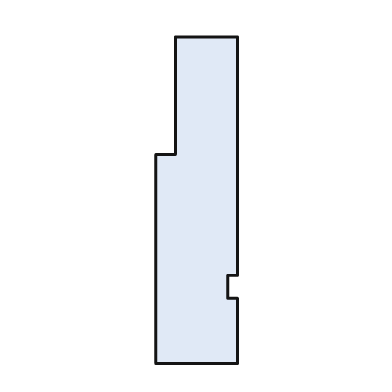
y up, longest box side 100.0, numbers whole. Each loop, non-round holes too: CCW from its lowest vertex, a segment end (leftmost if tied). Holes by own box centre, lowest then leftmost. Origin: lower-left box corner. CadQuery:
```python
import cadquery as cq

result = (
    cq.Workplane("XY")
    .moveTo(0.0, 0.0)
    .lineTo(25.0, 0.0)
    .lineTo(25.0, 20.0)
    .lineTo(22.0, 20.0)
    .lineTo(22.0, 27.0)
    .lineTo(25.0, 27.0)
    .lineTo(25.0, 100.0)
    .lineTo(6.0, 100.0)
    .lineTo(6.0, 64.0)
    .lineTo(0.0, 64.0)
    .close()
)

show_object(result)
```